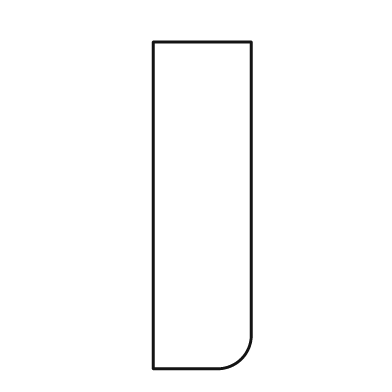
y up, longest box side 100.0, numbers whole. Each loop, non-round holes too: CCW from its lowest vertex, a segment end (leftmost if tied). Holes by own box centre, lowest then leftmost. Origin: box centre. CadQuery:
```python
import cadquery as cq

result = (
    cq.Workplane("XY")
    .moveTo(-15.0, -50.0)
    .lineTo(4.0, -50.0)
    .threePointArc((12.0, -47.0), (15.0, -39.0))
    .lineTo(15.0, 50.0)
    .lineTo(-15.0, 50.0)
    .close()
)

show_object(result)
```